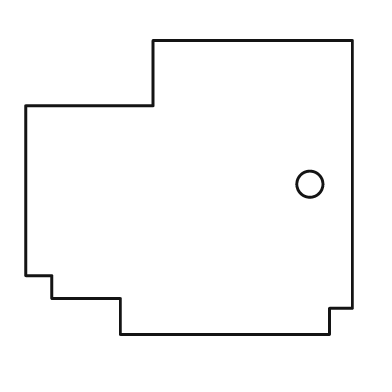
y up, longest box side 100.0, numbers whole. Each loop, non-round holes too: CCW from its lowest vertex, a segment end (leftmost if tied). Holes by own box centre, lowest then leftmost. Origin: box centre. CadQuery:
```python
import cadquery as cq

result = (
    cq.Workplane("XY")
    .moveTo(-21.0, -45.0)
    .lineTo(43.0, -45.0)
    .lineTo(43.0, -37.0)
    .lineTo(50.0, -37.0)
    .lineTo(50.0, 45.0)
    .lineTo(-11.0, 45.0)
    .lineTo(-11.0, 25.0)
    .lineTo(-50.0, 25.0)
    .lineTo(-50.0, -27.0)
    .lineTo(-42.0, -27.0)
    .lineTo(-42.0, -34.0)
    .lineTo(-21.0, -34.0)
    .close()
    .moveTo(37.0, 1.0)
    .circle(4.0)
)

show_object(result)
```